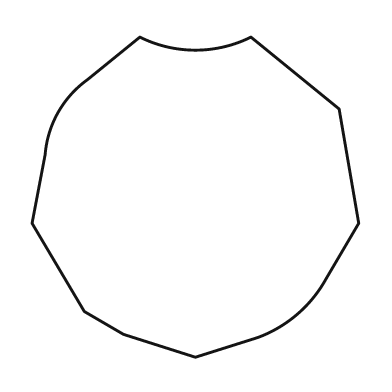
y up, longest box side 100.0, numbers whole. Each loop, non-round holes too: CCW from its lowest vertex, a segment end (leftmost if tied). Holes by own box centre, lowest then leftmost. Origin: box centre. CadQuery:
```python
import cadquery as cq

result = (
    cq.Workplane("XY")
    .moveTo(0.0, -49.0)
    .lineTo(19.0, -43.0)
    .threePointArc((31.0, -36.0), (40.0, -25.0))
    .lineTo(50.0, -8.0)
    .lineTo(44.0, 27.0)
    .lineTo(17.0, 49.0)
    .threePointArc((0.0, 45.0), (-17.0, 49.0))
    .lineTo(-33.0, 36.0)
    .threePointArc((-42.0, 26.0), (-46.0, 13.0))
    .lineTo(-50.0, -8.0)
    .lineTo(-34.0, -35.0)
    .lineTo(-22.0, -42.0)
    .close()
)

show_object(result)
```